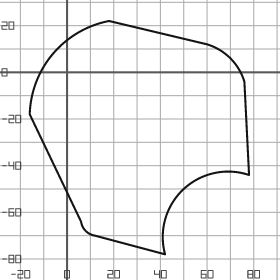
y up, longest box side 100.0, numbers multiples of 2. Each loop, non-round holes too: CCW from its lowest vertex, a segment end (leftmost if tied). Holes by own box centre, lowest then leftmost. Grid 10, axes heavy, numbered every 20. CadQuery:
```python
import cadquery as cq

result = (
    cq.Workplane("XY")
    .moveTo(42.0, -78.0)
    .threePointArc((50.0, -50.0), (78.0, -44.0))
    .lineTo(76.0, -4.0)
    .threePointArc((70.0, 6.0), (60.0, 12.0))
    .lineTo(18.0, 22.0)
    .threePointArc((-6.0, 8.0), (-16.0, -18.0))
    .lineTo(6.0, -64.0)
    .threePointArc((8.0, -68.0), (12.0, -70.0))
    .close()
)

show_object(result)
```